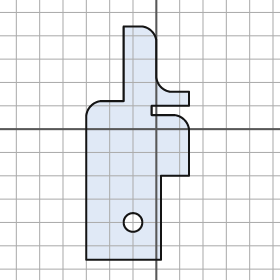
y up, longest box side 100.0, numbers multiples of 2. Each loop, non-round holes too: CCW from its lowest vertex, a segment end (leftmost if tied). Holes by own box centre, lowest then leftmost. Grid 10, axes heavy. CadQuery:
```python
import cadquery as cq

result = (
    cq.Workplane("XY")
    .moveTo(-30.0, -56.0)
    .lineTo(2.0, -56.0)
    .lineTo(2.0, -20.0)
    .lineTo(14.0, -20.0)
    .lineTo(14.0, 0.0)
    .threePointArc((12.0, 4.0), (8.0, 6.0))
    .lineTo(-2.0, 6.0)
    .lineTo(-2.0, 10.0)
    .lineTo(14.0, 10.0)
    .lineTo(14.0, 16.0)
    .lineTo(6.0, 16.0)
    .threePointArc((2.0, 18.0), (0.0, 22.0))
    .lineTo(0.0, 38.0)
    .threePointArc((-2.0, 42.0), (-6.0, 44.0))
    .lineTo(-14.0, 44.0)
    .lineTo(-14.0, 12.0)
    .lineTo(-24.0, 12.0)
    .threePointArc((-28.0, 10.0), (-30.0, 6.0))
    .close()
    .moveTo(-10.0, -40.0)
    .circle(4.0)
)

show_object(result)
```